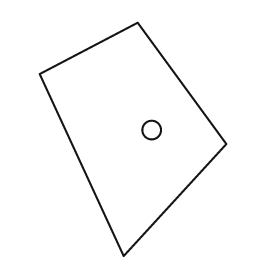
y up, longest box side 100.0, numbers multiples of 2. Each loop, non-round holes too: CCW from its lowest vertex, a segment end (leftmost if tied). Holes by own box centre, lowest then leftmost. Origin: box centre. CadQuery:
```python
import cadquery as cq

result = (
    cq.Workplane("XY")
    .moveTo(-4.0, -50.0)
    .lineTo(40.0, -2.0)
    .lineTo(2.0, 50.0)
    .lineTo(-40.0, 28.0)
    .close()
    .moveTo(8.0, 4.0)
    .circle(4.0)
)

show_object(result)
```